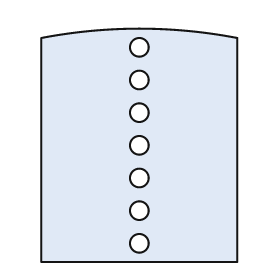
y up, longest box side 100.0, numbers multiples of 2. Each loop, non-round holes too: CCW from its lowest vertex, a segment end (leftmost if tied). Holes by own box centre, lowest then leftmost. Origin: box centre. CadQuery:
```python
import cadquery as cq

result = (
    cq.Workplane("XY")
    .moveTo(-42.0, -50.0)
    .lineTo(42.0, -50.0)
    .lineTo(42.0, 46.0)
    .threePointArc((0.0, 50.0), (-42.0, 46.0))
    .close()
    .moveTo(0.0, -42.0)
    .circle(4.0)
    .moveTo(0.0, -28.0)
    .circle(4.0)
    .moveTo(0.0, -14.0)
    .circle(4.0)
    .moveTo(0.0, 0.0)
    .circle(4.0)
    .moveTo(0.0, 14.0)
    .circle(4.0)
    .moveTo(0.0, 28.0)
    .circle(4.0)
    .moveTo(0.0, 42.0)
    .circle(4.0)
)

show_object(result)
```